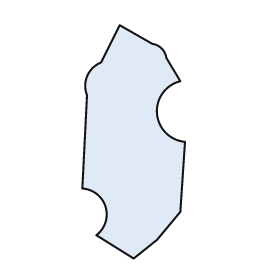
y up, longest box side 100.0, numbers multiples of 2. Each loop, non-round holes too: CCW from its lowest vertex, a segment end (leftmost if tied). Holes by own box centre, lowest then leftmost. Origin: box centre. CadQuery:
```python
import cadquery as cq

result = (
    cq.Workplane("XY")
    .moveTo(0.0, -50.0)
    .lineTo(10.0, -42.0)
    .lineTo(20.0, -30.0)
    .lineTo(22.0, 0.0)
    .threePointArc((10.0, 12.0), (20.0, 26.0))
    .lineTo(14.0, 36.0)
    .threePointArc((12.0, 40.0), (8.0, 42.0))
    .lineTo(-6.0, 50.0)
    .lineTo(-14.0, 34.0)
    .threePointArc((-20.0, 28.0), (-20.0, 20.0))
    .lineTo(-22.0, -20.0)
    .threePointArc((-12.0, -28.0), (-16.0, -40.0))
    .close()
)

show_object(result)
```